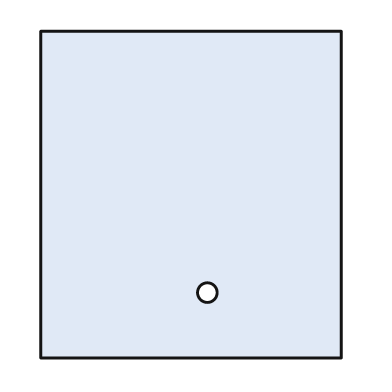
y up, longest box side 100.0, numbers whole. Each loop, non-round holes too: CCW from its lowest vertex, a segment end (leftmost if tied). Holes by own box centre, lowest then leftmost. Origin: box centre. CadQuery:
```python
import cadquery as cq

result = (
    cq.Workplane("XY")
    .moveTo(-46.0, -50.0)
    .lineTo(46.0, -50.0)
    .lineTo(46.0, 50.0)
    .lineTo(-46.0, 50.0)
    .close()
    .moveTo(5.0, -30.0)
    .circle(3.0)
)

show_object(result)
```